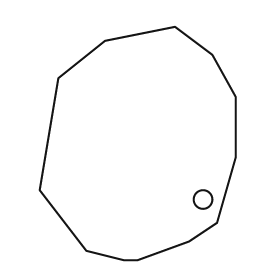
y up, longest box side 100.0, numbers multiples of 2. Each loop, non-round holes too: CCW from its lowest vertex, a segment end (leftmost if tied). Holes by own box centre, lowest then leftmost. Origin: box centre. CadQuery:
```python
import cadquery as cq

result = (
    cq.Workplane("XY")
    .moveTo(-6.0, -50.0)
    .lineTo(0.0, -50.0)
    .lineTo(22.0, -42.0)
    .lineTo(34.0, -34.0)
    .lineTo(42.0, -6.0)
    .lineTo(42.0, 20.0)
    .lineTo(32.0, 38.0)
    .lineTo(16.0, 50.0)
    .lineTo(-14.0, 44.0)
    .lineTo(-34.0, 28.0)
    .lineTo(-42.0, -20.0)
    .lineTo(-22.0, -46.0)
    .close()
    .moveTo(28.0, -24.0)
    .circle(4.0)
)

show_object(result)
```